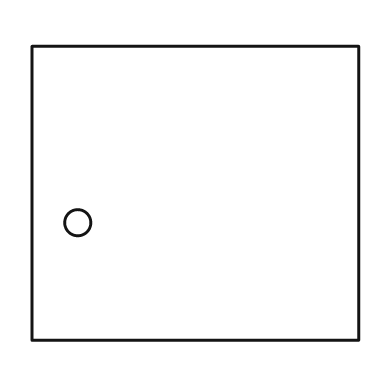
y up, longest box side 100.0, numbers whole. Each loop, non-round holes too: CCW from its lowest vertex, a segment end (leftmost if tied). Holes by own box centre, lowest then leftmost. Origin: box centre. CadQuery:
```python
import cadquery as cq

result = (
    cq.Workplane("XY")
    .moveTo(-50.0, -45.0)
    .lineTo(50.0, -45.0)
    .lineTo(50.0, 45.0)
    .lineTo(-50.0, 45.0)
    .close()
    .moveTo(-36.0, -9.0)
    .circle(4.0)
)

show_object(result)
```